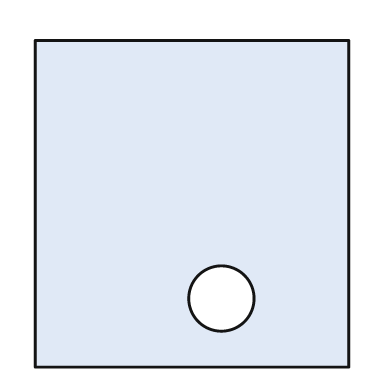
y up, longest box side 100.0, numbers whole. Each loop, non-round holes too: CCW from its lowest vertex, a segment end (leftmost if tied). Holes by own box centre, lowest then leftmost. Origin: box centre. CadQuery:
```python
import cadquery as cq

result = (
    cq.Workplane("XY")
    .moveTo(-48.0, -50.0)
    .lineTo(48.0, -50.0)
    .lineTo(48.0, 50.0)
    .lineTo(-48.0, 50.0)
    .close()
    .moveTo(9.0, -29.0)
    .circle(10.0)
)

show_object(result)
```